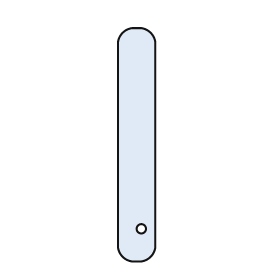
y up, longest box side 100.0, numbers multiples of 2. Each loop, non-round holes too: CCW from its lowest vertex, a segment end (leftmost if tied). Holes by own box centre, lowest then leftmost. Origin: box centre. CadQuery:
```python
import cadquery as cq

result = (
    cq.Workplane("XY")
    .moveTo(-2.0, -50.0)
    .lineTo(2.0, -50.0)
    .threePointArc((6.0, -48.0), (8.0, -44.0))
    .lineTo(8.0, 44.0)
    .threePointArc((6.0, 48.0), (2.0, 50.0))
    .lineTo(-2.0, 50.0)
    .threePointArc((-6.0, 48.0), (-8.0, 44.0))
    .lineTo(-8.0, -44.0)
    .threePointArc((-6.0, -48.0), (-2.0, -50.0))
    .close()
    .moveTo(2.0, -36.0)
    .circle(2.0)
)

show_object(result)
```